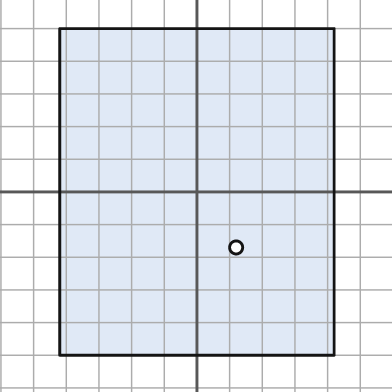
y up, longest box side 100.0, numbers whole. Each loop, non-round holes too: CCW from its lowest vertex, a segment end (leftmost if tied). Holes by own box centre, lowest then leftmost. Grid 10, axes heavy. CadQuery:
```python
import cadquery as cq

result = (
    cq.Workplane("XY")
    .moveTo(-42.0, -50.0)
    .lineTo(42.0, -50.0)
    .lineTo(42.0, 50.0)
    .lineTo(-42.0, 50.0)
    .close()
    .moveTo(12.0, -17.0)
    .circle(2.0)
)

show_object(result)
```